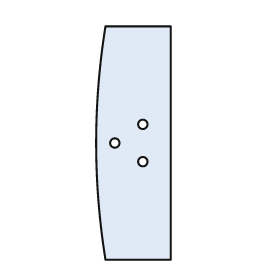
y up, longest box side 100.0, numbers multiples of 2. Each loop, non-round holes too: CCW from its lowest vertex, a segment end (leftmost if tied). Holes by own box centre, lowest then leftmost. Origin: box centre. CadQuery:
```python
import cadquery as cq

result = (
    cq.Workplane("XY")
    .moveTo(-12.0, -50.0)
    .lineTo(16.0, -50.0)
    .lineTo(16.0, 50.0)
    .lineTo(-12.0, 50.0)
    .threePointArc((-16.0, 0.0), (-12.0, -50.0))
    .close()
    .moveTo(4.0, -8.0)
    .circle(2.0)
    .moveTo(-8.0, 0.0)
    .circle(2.0)
    .moveTo(4.0, 8.0)
    .circle(2.0)
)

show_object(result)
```